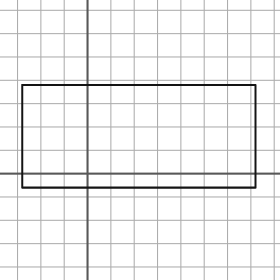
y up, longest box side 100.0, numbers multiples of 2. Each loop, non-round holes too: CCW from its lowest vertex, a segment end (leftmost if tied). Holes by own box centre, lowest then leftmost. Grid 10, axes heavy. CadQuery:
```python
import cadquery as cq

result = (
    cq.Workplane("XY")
    .moveTo(-28.0, -6.0)
    .lineTo(72.0, -6.0)
    .lineTo(72.0, 38.0)
    .lineTo(-28.0, 38.0)
    .close()
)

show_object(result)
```